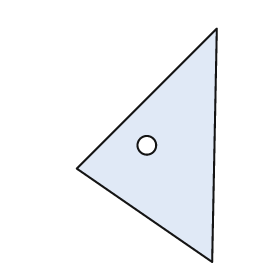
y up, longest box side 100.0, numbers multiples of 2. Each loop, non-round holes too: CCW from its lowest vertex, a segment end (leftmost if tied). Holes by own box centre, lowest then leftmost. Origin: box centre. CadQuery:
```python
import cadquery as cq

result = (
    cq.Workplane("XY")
    .moveTo(28.0, -50.0)
    .lineTo(30.0, 50.0)
    .lineTo(-30.0, -10.0)
    .close()
    .moveTo(0.0, 0.0)
    .circle(4.0)
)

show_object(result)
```